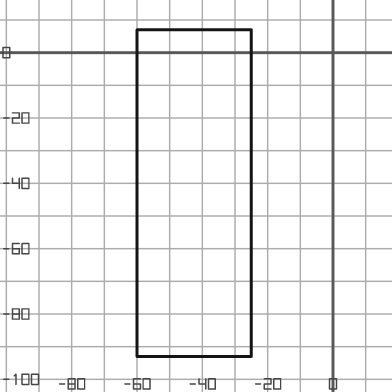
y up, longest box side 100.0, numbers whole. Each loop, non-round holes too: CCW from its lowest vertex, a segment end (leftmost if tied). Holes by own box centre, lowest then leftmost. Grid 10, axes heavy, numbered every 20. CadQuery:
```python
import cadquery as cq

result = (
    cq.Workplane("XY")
    .moveTo(-60.0, -93.0)
    .lineTo(-25.0, -93.0)
    .lineTo(-25.0, 7.0)
    .lineTo(-60.0, 7.0)
    .close()
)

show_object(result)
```